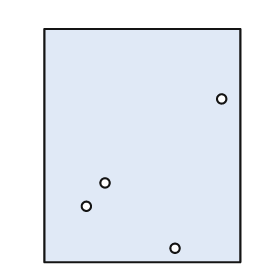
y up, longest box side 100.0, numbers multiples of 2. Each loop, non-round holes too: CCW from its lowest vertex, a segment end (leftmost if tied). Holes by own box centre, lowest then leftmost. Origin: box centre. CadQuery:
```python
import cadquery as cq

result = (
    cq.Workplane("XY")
    .moveTo(-42.0, -50.0)
    .lineTo(42.0, -50.0)
    .lineTo(42.0, 50.0)
    .lineTo(-42.0, 50.0)
    .close()
    .moveTo(14.0, -44.0)
    .circle(2.0)
    .moveTo(-24.0, -26.0)
    .circle(2.0)
    .moveTo(-16.0, -16.0)
    .circle(2.0)
    .moveTo(34.0, 20.0)
    .circle(2.0)
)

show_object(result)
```